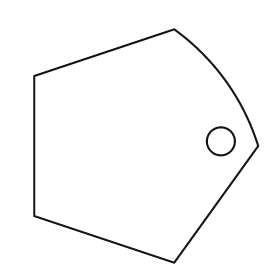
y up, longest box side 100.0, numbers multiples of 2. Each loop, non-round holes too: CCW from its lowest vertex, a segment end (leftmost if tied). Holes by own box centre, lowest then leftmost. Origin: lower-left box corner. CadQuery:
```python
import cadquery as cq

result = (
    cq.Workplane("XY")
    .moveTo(60.0, 0.0)
    .lineTo(96.0, 50.0)
    .threePointArc((82.0, 78.0), (60.0, 100.0))
    .lineTo(0.0, 80.0)
    .lineTo(0.0, 20.0)
    .close()
    .moveTo(80.0, 52.0)
    .circle(6.0)
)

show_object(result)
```